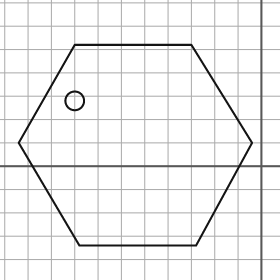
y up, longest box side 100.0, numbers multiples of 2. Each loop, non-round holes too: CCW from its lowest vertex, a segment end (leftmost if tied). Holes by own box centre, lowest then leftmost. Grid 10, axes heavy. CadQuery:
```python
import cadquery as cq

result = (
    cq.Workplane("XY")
    .moveTo(-78.0, -34.0)
    .lineTo(-28.0, -34.0)
    .lineTo(-4.0, 10.0)
    .lineTo(-30.0, 52.0)
    .lineTo(-80.0, 52.0)
    .lineTo(-104.0, 10.0)
    .close()
    .moveTo(-80.0, 28.0)
    .circle(4.0)
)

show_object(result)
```